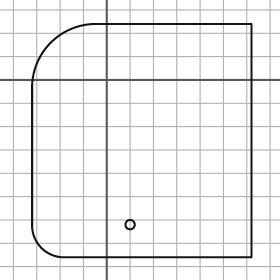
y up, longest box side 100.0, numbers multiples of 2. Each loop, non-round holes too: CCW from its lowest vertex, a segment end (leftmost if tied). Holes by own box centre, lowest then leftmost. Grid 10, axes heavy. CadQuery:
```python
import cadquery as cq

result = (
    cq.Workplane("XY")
    .moveTo(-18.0, -76.0)
    .lineTo(62.0, -76.0)
    .lineTo(62.0, 24.0)
    .lineTo(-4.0, 24.0)
    .threePointArc((-24.0, 16.0), (-32.0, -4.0))
    .lineTo(-32.0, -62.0)
    .threePointArc((-28.0, -72.0), (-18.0, -76.0))
    .close()
    .moveTo(10.0, -62.0)
    .circle(2.0)
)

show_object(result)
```